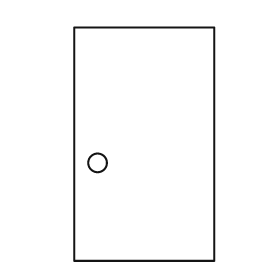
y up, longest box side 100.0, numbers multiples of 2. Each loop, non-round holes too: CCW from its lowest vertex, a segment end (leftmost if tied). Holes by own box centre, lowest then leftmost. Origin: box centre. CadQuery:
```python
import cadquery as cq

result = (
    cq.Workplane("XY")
    .moveTo(-30.0, -50.0)
    .lineTo(30.0, -50.0)
    .lineTo(30.0, 50.0)
    .lineTo(-30.0, 50.0)
    .close()
    .moveTo(-20.0, -8.0)
    .circle(4.0)
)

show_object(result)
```